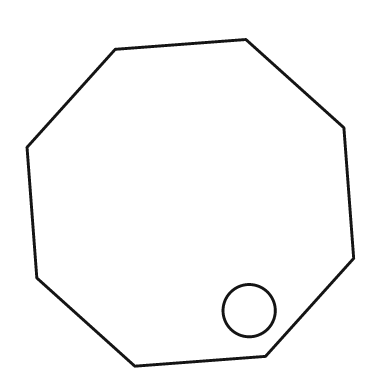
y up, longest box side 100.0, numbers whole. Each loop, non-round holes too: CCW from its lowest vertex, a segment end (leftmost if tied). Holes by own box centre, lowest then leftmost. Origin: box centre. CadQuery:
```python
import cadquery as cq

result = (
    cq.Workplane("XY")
    .moveTo(-17.0, -50.0)
    .lineTo(23.0, -47.0)
    .lineTo(50.0, -17.0)
    .lineTo(47.0, 23.0)
    .lineTo(17.0, 50.0)
    .lineTo(-23.0, 47.0)
    .lineTo(-50.0, 17.0)
    .lineTo(-47.0, -23.0)
    .close()
    .moveTo(18.0, -33.0)
    .circle(8.0)
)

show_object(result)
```